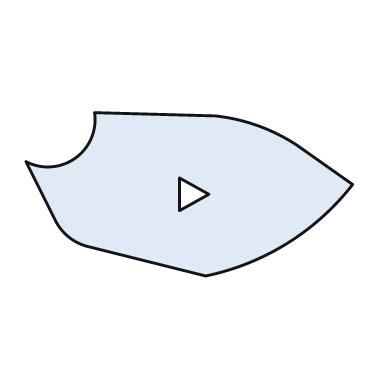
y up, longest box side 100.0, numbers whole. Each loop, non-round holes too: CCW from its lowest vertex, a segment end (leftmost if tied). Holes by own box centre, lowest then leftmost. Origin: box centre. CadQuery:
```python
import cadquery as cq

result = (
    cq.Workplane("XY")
    .moveTo(5.0, -25.0)
    .threePointArc((30.0, -15.0), (50.0, 3.0))
    .lineTo(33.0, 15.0)
    .threePointArc((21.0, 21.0), (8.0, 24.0))
    .lineTo(-29.0, 25.0)
    .threePointArc((-35.0, 11.0), (-50.0, 10.0))
    .lineTo(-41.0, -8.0)
    .threePointArc((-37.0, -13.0), (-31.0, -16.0))
    .close()
    .moveTo(-3.0, -5.0)
    .lineTo(6.0, 0.0)
    .lineTo(-3.0, 5.0)
    .close()
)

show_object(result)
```